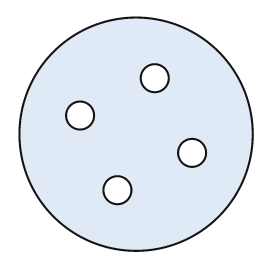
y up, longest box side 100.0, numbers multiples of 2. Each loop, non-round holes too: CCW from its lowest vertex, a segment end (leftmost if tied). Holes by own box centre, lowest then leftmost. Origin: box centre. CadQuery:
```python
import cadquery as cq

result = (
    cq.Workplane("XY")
    .moveTo(0.0, 0.0)
    .circle(50.0)
    .moveTo(-8.0, -24.0)
    .circle(6.0)
    .moveTo(24.0, -8.0)
    .circle(6.0)
    .moveTo(-24.0, 8.0)
    .circle(6.0)
    .moveTo(8.0, 24.0)
    .circle(6.0)
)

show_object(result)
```